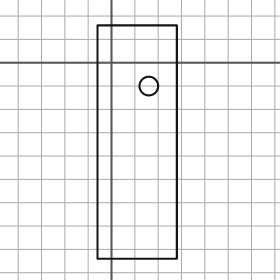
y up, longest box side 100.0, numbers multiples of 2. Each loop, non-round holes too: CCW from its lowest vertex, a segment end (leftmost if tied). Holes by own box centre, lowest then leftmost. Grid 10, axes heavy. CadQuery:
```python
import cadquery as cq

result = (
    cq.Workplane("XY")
    .moveTo(-6.0, -84.0)
    .lineTo(28.0, -84.0)
    .lineTo(28.0, 16.0)
    .lineTo(-6.0, 16.0)
    .close()
    .moveTo(16.0, -10.0)
    .circle(4.0)
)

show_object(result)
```